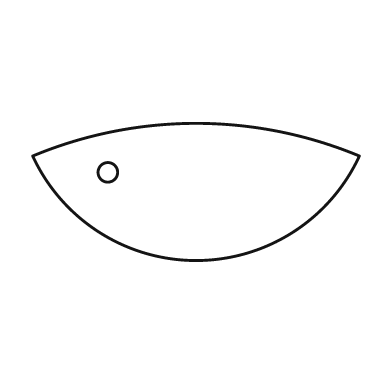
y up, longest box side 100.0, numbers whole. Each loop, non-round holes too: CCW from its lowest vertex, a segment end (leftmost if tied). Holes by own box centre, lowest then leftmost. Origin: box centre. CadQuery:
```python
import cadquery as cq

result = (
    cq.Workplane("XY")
    .moveTo(-50.0, 11.0)
    .threePointArc((0.0, -21.0), (50.0, 11.0))
    .threePointArc((0.0, 21.0), (-50.0, 11.0))
    .close()
    .moveTo(-27.0, 6.0)
    .circle(3.0)
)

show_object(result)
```